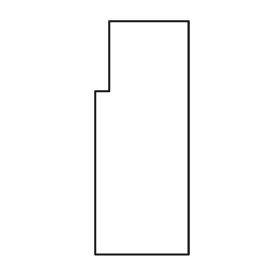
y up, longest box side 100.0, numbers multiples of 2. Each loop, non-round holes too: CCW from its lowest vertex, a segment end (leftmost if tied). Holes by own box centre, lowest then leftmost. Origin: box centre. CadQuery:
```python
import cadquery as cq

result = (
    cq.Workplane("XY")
    .moveTo(-20.0, -50.0)
    .lineTo(20.0, -50.0)
    .lineTo(20.0, 50.0)
    .lineTo(-14.0, 50.0)
    .lineTo(-14.0, 20.0)
    .lineTo(-20.0, 20.0)
    .close()
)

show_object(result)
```